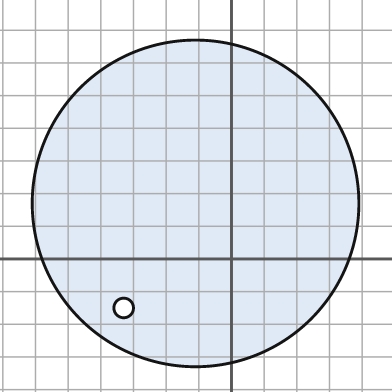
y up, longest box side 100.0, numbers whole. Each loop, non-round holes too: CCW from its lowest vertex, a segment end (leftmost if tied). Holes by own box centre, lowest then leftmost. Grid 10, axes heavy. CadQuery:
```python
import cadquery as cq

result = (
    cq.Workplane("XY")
    .moveTo(-11.0, 17.0)
    .circle(50.0)
    .moveTo(-33.0, -15.0)
    .circle(3.0)
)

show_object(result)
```